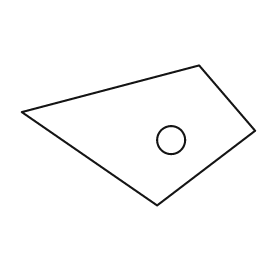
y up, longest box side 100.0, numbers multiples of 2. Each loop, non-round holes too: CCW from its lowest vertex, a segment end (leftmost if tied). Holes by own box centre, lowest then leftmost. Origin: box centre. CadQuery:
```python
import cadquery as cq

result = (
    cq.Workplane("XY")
    .moveTo(8.0, -30.0)
    .lineTo(50.0, 2.0)
    .lineTo(26.0, 30.0)
    .lineTo(-50.0, 10.0)
    .close()
    .moveTo(14.0, -2.0)
    .circle(6.0)
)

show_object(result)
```